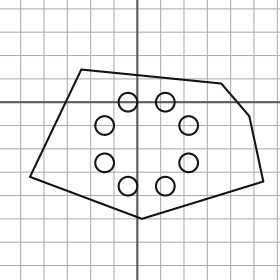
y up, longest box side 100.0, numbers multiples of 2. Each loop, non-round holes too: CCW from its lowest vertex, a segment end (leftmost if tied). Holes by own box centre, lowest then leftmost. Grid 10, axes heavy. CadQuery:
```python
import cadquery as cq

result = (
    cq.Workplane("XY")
    .moveTo(2.0, -50.0)
    .lineTo(54.0, -34.0)
    .lineTo(48.0, -6.0)
    .lineTo(36.0, 8.0)
    .lineTo(-24.0, 14.0)
    .lineTo(-46.0, -32.0)
    .close()
    .moveTo(-4.0, -36.0)
    .circle(4.0)
    .moveTo(12.0, -36.0)
    .circle(4.0)
    .moveTo(-14.0, -26.0)
    .circle(4.0)
    .moveTo(22.0, -26.0)
    .circle(4.0)
    .moveTo(-14.0, -10.0)
    .circle(4.0)
    .moveTo(22.0, -10.0)
    .circle(4.0)
    .moveTo(-4.0, 0.0)
    .circle(4.0)
    .moveTo(12.0, 0.0)
    .circle(4.0)
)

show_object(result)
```